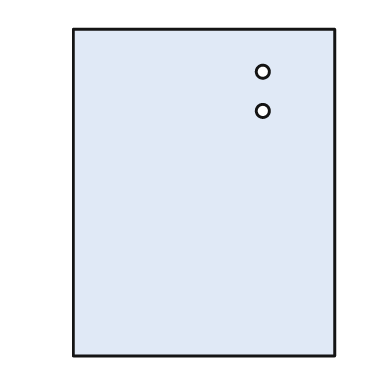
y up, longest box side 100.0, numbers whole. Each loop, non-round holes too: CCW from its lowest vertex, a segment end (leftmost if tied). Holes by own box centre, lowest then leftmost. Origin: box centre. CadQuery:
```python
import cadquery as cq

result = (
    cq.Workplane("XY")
    .moveTo(-40.0, -50.0)
    .lineTo(40.0, -50.0)
    .lineTo(40.0, 50.0)
    .lineTo(-40.0, 50.0)
    .close()
    .moveTo(18.0, 25.0)
    .circle(2.0)
    .moveTo(18.0, 37.0)
    .circle(2.0)
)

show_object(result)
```